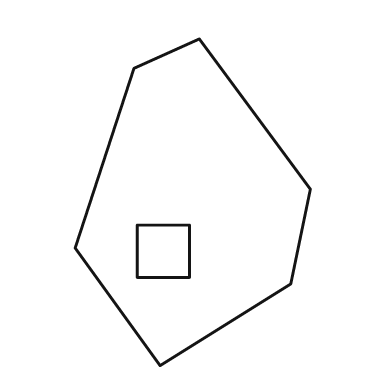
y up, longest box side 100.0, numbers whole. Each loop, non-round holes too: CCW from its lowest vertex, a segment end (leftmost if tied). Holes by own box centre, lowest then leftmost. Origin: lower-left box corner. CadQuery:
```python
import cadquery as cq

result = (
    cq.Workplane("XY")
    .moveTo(26.0, 0.0)
    .lineTo(66.0, 25.0)
    .lineTo(72.0, 54.0)
    .lineTo(38.0, 100.0)
    .lineTo(18.0, 91.0)
    .lineTo(0.0, 36.0)
    .close()
    .moveTo(19.0, 27.0)
    .lineTo(35.0, 27.0)
    .lineTo(35.0, 43.0)
    .lineTo(19.0, 43.0)
    .close()
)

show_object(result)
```